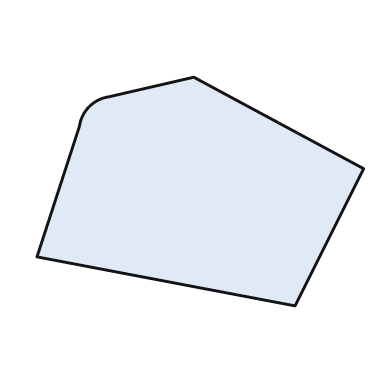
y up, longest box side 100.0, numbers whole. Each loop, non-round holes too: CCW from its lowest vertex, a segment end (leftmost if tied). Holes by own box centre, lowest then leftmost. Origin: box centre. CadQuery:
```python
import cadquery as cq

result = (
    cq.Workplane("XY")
    .moveTo(29.0, -35.0)
    .lineTo(50.0, 7.0)
    .lineTo(-2.0, 35.0)
    .lineTo(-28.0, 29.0)
    .threePointArc((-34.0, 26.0), (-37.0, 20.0))
    .lineTo(-50.0, -20.0)
    .close()
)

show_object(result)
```